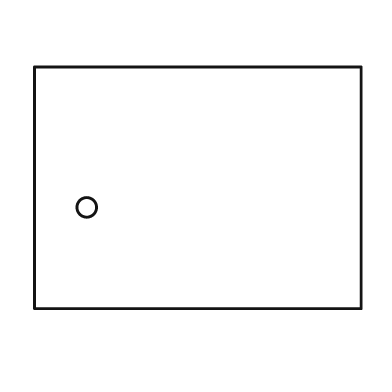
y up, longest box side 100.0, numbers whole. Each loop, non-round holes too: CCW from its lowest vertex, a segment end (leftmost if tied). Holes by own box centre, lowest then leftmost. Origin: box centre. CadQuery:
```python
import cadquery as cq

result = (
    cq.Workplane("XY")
    .moveTo(-50.0, -37.0)
    .lineTo(50.0, -37.0)
    .lineTo(50.0, 37.0)
    .lineTo(-50.0, 37.0)
    .close()
    .moveTo(-34.0, -6.0)
    .circle(3.0)
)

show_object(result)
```